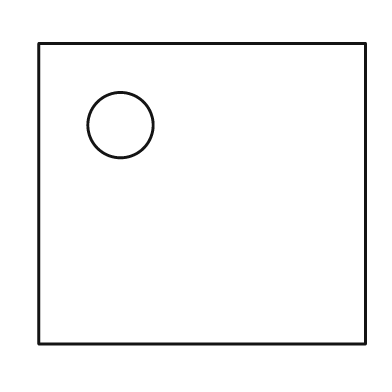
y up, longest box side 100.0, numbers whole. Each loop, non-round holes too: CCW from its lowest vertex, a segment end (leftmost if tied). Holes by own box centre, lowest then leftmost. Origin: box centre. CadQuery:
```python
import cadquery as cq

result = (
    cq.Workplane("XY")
    .moveTo(-50.0, -46.0)
    .lineTo(50.0, -46.0)
    .lineTo(50.0, 46.0)
    .lineTo(-50.0, 46.0)
    .close()
    .moveTo(-25.0, 21.0)
    .circle(10.0)
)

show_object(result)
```